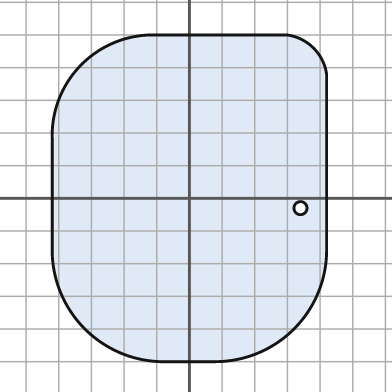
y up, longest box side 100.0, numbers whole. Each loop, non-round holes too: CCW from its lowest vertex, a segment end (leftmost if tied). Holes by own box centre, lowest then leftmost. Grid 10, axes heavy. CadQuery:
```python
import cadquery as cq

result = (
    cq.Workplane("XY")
    .moveTo(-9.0, -50.0)
    .lineTo(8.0, -50.0)
    .threePointArc((32.0, -40.0), (42.0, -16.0))
    .lineTo(42.0, 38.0)
    .threePointArc((38.0, 46.0), (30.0, 50.0))
    .lineTo(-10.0, 50.0)
    .threePointArc((-33.0, 41.0), (-42.0, 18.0))
    .lineTo(-42.0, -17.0)
    .threePointArc((-32.0, -40.0), (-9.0, -50.0))
    .close()
    .moveTo(34.0, -3.0)
    .circle(2.0)
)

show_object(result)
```